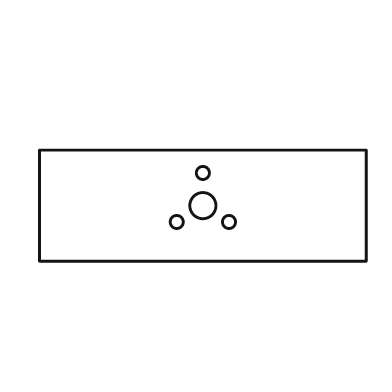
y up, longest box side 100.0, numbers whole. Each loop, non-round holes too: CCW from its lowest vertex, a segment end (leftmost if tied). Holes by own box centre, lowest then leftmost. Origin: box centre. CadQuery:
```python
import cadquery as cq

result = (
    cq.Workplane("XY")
    .moveTo(-50.0, -17.0)
    .lineTo(50.0, -17.0)
    .lineTo(50.0, 17.0)
    .lineTo(-50.0, 17.0)
    .close()
    .moveTo(-8.0, -5.0)
    .circle(2.0)
    .moveTo(8.0, -5.0)
    .circle(2.0)
    .moveTo(0.0, 0.0)
    .circle(4.0)
    .moveTo(0.0, 10.0)
    .circle(2.0)
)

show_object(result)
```